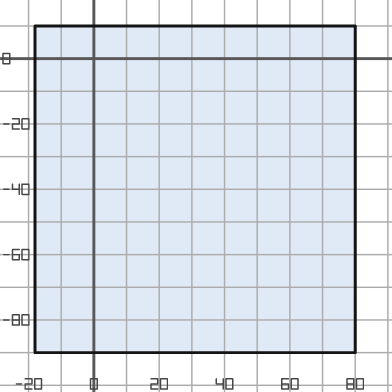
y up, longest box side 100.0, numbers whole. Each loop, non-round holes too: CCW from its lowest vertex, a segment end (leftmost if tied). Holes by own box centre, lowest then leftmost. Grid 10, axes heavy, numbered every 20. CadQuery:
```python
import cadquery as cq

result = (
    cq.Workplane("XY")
    .moveTo(-18.0, -90.0)
    .lineTo(80.0, -90.0)
    .lineTo(80.0, 10.0)
    .lineTo(-18.0, 10.0)
    .close()
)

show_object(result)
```